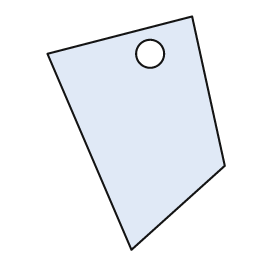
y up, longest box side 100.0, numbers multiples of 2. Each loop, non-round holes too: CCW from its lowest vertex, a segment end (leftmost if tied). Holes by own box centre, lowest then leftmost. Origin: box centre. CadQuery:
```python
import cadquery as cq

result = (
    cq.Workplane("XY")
    .moveTo(-2.0, -50.0)
    .lineTo(38.0, -14.0)
    .lineTo(24.0, 50.0)
    .lineTo(-38.0, 34.0)
    .close()
    .moveTo(6.0, 34.0)
    .circle(6.0)
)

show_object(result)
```